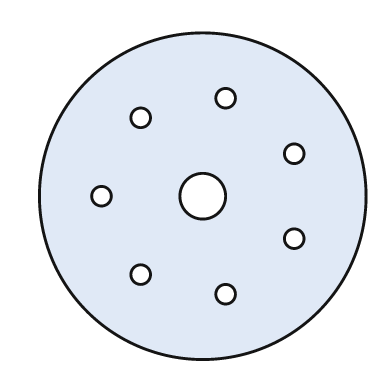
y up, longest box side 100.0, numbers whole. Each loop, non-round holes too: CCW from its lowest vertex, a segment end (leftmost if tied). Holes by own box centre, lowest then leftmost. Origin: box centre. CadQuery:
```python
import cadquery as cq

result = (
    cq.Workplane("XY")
    .moveTo(0.0, 0.0)
    .circle(50.0)
    .moveTo(7.0, -30.0)
    .circle(3.0)
    .moveTo(-19.0, -24.0)
    .circle(3.0)
    .moveTo(28.0, -13.0)
    .circle(3.0)
    .moveTo(-31.0, 0.0)
    .circle(3.0)
    .moveTo(0.0, 0.0)
    .circle(7.0)
    .moveTo(28.0, 13.0)
    .circle(3.0)
    .moveTo(-19.0, 24.0)
    .circle(3.0)
    .moveTo(7.0, 30.0)
    .circle(3.0)
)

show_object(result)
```